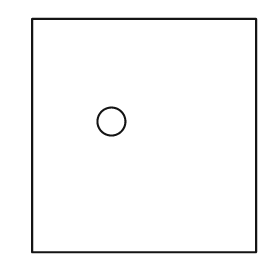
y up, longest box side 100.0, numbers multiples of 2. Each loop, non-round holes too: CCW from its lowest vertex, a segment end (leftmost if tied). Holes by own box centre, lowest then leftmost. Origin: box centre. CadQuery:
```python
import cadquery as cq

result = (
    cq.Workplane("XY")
    .moveTo(-48.0, -50.0)
    .lineTo(48.0, -50.0)
    .lineTo(48.0, 50.0)
    .lineTo(-48.0, 50.0)
    .close()
    .moveTo(-14.0, 6.0)
    .circle(6.0)
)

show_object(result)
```